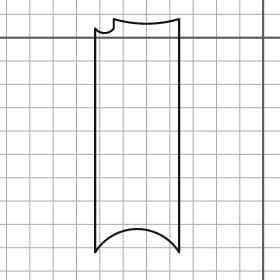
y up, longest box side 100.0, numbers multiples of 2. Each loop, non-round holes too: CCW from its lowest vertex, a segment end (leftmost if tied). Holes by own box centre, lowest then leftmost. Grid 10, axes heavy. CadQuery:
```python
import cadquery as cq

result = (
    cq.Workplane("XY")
    .moveTo(-72.0, -92.0)
    .threePointArc((-54.0, -82.0), (-36.0, -92.0))
    .lineTo(-36.0, 8.0)
    .threePointArc((-50.0, 6.0), (-64.0, 8.0))
    .lineTo(-64.0, 4.0)
    .threePointArc((-68.0, 2.0), (-72.0, 4.0))
    .close()
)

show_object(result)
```